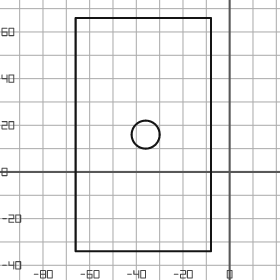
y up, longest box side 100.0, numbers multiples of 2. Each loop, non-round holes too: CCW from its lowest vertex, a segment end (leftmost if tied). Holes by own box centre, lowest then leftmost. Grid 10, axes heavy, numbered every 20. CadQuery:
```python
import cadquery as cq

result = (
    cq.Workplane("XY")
    .moveTo(-66.0, -34.0)
    .lineTo(-8.0, -34.0)
    .lineTo(-8.0, 66.0)
    .lineTo(-66.0, 66.0)
    .close()
    .moveTo(-36.0, 16.0)
    .circle(6.0)
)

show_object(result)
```